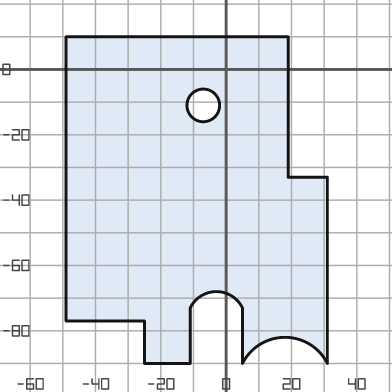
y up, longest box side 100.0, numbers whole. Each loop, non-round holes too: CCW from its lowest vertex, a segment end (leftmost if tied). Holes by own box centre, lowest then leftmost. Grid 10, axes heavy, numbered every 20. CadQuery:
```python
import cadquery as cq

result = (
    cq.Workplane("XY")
    .moveTo(-25.0, -90.0)
    .lineTo(-11.0, -90.0)
    .lineTo(-11.0, -73.0)
    .threePointArc((-3.0, -68.0), (5.0, -73.0))
    .lineTo(5.0, -90.0)
    .threePointArc((18.0, -82.0), (31.0, -90.0))
    .lineTo(31.0, -33.0)
    .lineTo(19.0, -33.0)
    .lineTo(19.0, 10.0)
    .lineTo(-49.0, 10.0)
    .lineTo(-49.0, -77.0)
    .lineTo(-25.0, -77.0)
    .close()
    .moveTo(-7.0, -11.0)
    .circle(5.0)
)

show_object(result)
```